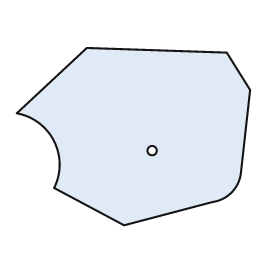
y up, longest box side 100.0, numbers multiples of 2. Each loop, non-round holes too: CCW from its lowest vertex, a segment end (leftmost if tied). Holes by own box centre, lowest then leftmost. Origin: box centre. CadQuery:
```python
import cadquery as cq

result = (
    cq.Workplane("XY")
    .moveTo(-4.0, -38.0)
    .lineTo(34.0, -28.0)
    .threePointArc((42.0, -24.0), (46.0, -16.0))
    .lineTo(50.0, 20.0)
    .lineTo(40.0, 36.0)
    .lineTo(-20.0, 38.0)
    .lineTo(-50.0, 10.0)
    .threePointArc((-34.0, -2.0), (-34.0, -22.0))
    .close()
    .moveTo(8.0, -6.0)
    .circle(2.0)
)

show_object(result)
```